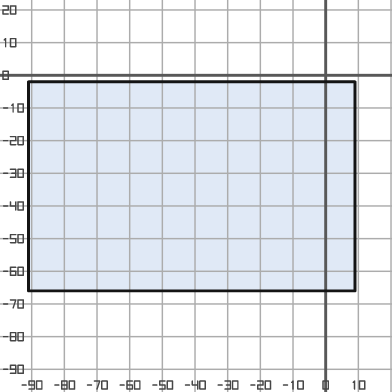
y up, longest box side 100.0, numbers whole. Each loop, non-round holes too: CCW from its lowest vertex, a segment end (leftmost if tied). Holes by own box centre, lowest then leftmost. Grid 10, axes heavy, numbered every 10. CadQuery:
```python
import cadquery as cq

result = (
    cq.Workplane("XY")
    .moveTo(-91.0, -66.0)
    .lineTo(9.0, -66.0)
    .lineTo(9.0, -2.0)
    .lineTo(-91.0, -2.0)
    .close()
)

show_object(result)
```